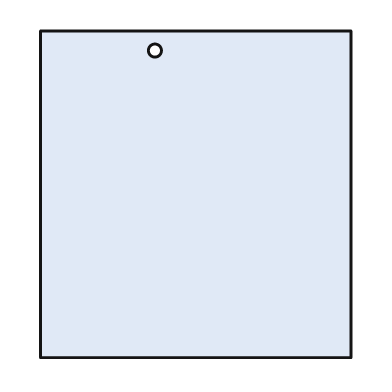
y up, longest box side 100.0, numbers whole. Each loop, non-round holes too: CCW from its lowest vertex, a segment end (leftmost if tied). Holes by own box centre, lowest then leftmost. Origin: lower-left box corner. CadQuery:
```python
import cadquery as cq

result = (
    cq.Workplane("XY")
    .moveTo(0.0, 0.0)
    .lineTo(95.0, 0.0)
    .lineTo(95.0, 100.0)
    .lineTo(0.0, 100.0)
    .close()
    .moveTo(35.0, 94.0)
    .circle(2.0)
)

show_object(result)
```